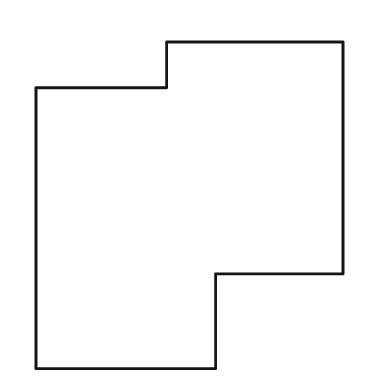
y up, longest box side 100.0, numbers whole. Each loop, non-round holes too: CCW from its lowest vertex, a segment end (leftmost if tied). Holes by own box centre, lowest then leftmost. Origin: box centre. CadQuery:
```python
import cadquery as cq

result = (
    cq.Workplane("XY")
    .moveTo(-47.0, -50.0)
    .lineTo(8.0, -50.0)
    .lineTo(8.0, -21.0)
    .lineTo(47.0, -21.0)
    .lineTo(47.0, 50.0)
    .lineTo(-7.0, 50.0)
    .lineTo(-7.0, 36.0)
    .lineTo(-47.0, 36.0)
    .close()
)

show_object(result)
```